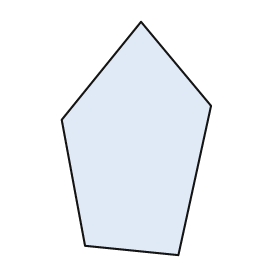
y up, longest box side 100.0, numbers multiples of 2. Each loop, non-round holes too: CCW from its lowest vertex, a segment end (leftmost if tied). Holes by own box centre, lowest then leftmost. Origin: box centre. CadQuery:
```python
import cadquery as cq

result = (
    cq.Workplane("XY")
    .moveTo(18.0, -50.0)
    .lineTo(32.0, 14.0)
    .lineTo(2.0, 50.0)
    .lineTo(-32.0, 8.0)
    .lineTo(-22.0, -46.0)
    .close()
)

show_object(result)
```